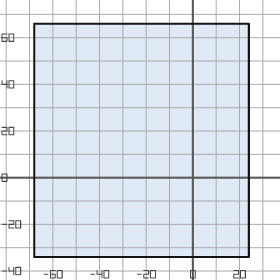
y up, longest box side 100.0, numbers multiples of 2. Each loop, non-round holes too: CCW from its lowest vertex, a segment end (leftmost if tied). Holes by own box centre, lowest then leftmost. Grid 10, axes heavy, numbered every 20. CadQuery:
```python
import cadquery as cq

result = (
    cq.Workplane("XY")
    .moveTo(-68.0, -34.0)
    .lineTo(24.0, -34.0)
    .lineTo(24.0, 66.0)
    .lineTo(-68.0, 66.0)
    .close()
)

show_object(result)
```